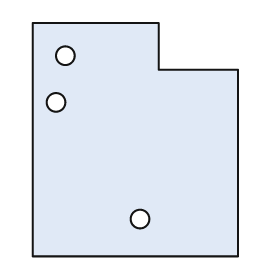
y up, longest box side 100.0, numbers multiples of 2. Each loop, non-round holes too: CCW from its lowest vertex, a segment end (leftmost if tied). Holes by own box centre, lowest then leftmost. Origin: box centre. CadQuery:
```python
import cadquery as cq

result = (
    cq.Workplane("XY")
    .moveTo(-44.0, -50.0)
    .lineTo(44.0, -50.0)
    .lineTo(44.0, 30.0)
    .lineTo(10.0, 30.0)
    .lineTo(10.0, 50.0)
    .lineTo(-44.0, 50.0)
    .close()
    .moveTo(2.0, -34.0)
    .circle(4.0)
    .moveTo(-34.0, 16.0)
    .circle(4.0)
    .moveTo(-30.0, 36.0)
    .circle(4.0)
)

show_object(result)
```